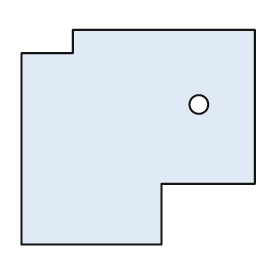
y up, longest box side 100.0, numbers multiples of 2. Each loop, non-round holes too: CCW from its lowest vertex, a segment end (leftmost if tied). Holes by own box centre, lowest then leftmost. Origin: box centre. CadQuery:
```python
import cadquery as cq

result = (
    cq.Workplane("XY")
    .moveTo(-50.0, -46.0)
    .lineTo(10.0, -46.0)
    .lineTo(10.0, -20.0)
    .lineTo(50.0, -20.0)
    .lineTo(50.0, 46.0)
    .lineTo(-28.0, 46.0)
    .lineTo(-28.0, 36.0)
    .lineTo(-50.0, 36.0)
    .close()
    .moveTo(26.0, 14.0)
    .circle(4.0)
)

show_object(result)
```